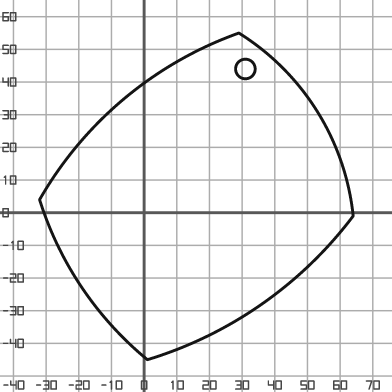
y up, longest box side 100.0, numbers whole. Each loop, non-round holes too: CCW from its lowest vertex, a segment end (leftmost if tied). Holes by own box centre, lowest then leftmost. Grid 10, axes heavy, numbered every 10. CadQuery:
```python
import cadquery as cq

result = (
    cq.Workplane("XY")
    .moveTo(1.0, -45.0)
    .threePointArc((36.0, -28.0), (64.0, -1.0))
    .threePointArc((53.0, 31.0), (29.0, 55.0))
    .threePointArc((-6.0, 35.0), (-32.0, 4.0))
    .threePointArc((-19.0, -23.0), (1.0, -45.0))
    .close()
    .moveTo(31.0, 44.0)
    .circle(3.0)
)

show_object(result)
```